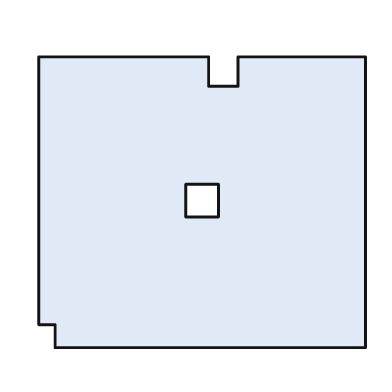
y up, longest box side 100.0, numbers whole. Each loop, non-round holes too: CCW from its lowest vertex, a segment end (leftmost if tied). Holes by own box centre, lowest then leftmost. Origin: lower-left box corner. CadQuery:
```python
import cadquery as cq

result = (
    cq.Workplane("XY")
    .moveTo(5.0, 0.0)
    .lineTo(100.0, 0.0)
    .lineTo(100.0, 89.0)
    .lineTo(61.0, 89.0)
    .lineTo(61.0, 80.0)
    .lineTo(52.0, 80.0)
    .lineTo(52.0, 89.0)
    .lineTo(0.0, 89.0)
    .lineTo(0.0, 7.0)
    .lineTo(5.0, 7.0)
    .close()
    .moveTo(45.0, 40.0)
    .lineTo(55.0, 40.0)
    .lineTo(55.0, 50.0)
    .lineTo(45.0, 50.0)
    .close()
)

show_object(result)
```